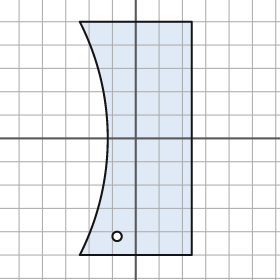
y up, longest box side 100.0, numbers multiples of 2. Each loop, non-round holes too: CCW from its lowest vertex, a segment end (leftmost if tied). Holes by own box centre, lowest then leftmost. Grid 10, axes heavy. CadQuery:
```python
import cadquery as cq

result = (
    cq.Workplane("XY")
    .moveTo(-24.0, -50.0)
    .lineTo(24.0, -50.0)
    .lineTo(24.0, 50.0)
    .lineTo(-24.0, 50.0)
    .threePointArc((-12.0, 0.0), (-24.0, -50.0))
    .close()
    .moveTo(-8.0, -42.0)
    .circle(2.0)
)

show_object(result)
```